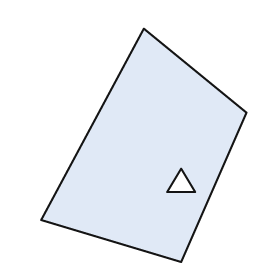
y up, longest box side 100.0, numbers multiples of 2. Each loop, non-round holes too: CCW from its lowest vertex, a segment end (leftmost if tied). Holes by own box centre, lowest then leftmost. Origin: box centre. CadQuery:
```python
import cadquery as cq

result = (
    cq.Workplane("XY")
    .moveTo(16.0, -50.0)
    .lineTo(44.0, 14.0)
    .lineTo(0.0, 50.0)
    .lineTo(-44.0, -32.0)
    .close()
    .moveTo(10.0, -20.0)
    .lineTo(22.0, -20.0)
    .lineTo(16.0, -10.0)
    .close()
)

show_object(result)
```